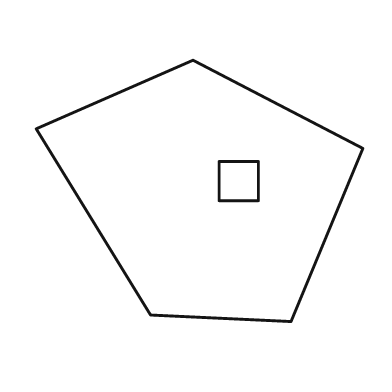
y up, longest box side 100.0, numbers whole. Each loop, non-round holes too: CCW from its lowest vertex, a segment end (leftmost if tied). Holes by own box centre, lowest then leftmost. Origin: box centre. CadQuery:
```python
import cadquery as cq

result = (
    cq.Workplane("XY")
    .moveTo(28.0, -40.0)
    .lineTo(50.0, 13.0)
    .lineTo(-2.0, 40.0)
    .lineTo(-50.0, 19.0)
    .lineTo(-15.0, -38.0)
    .close()
    .moveTo(6.0, -3.0)
    .lineTo(18.0, -3.0)
    .lineTo(18.0, 9.0)
    .lineTo(6.0, 9.0)
    .close()
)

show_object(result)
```